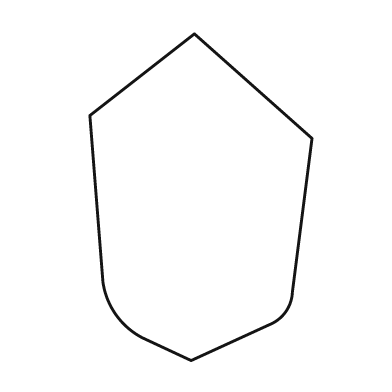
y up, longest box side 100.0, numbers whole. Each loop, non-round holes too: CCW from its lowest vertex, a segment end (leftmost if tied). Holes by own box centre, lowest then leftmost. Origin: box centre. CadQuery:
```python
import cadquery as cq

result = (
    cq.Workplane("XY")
    .moveTo(-3.0, -50.0)
    .lineTo(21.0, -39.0)
    .threePointArc((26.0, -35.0), (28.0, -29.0))
    .lineTo(34.0, 18.0)
    .lineTo(-2.0, 50.0)
    .lineTo(-34.0, 25.0)
    .lineTo(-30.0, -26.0)
    .threePointArc((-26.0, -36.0), (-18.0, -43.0))
    .close()
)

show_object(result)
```